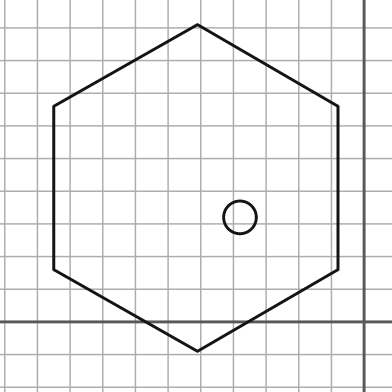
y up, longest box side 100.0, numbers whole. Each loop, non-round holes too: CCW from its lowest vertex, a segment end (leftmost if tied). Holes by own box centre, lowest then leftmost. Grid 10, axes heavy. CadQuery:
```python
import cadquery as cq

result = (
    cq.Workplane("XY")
    .moveTo(-51.0, -9.0)
    .lineTo(-8.0, 16.0)
    .lineTo(-8.0, 66.0)
    .lineTo(-51.0, 91.0)
    .lineTo(-95.0, 66.0)
    .lineTo(-95.0, 16.0)
    .close()
    .moveTo(-38.0, 32.0)
    .circle(5.0)
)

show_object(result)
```